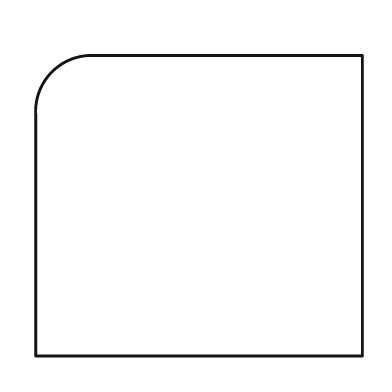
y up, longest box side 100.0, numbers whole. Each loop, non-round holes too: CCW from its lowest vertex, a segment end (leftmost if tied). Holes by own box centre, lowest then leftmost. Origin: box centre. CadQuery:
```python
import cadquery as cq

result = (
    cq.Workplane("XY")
    .moveTo(-50.0, -46.0)
    .lineTo(50.0, -46.0)
    .lineTo(50.0, 46.0)
    .lineTo(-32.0, 46.0)
    .threePointArc((-45.0, 41.0), (-50.0, 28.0))
    .close()
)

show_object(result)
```